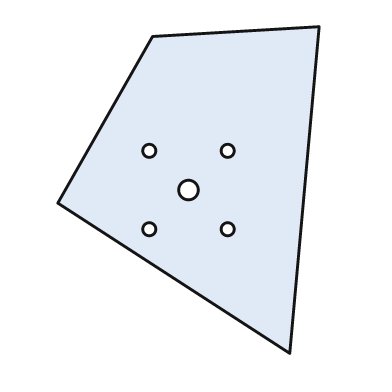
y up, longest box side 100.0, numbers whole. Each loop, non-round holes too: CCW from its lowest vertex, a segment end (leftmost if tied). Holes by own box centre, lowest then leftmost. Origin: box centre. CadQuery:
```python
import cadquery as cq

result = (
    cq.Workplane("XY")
    .moveTo(31.0, -50.0)
    .lineTo(40.0, 50.0)
    .lineTo(-11.0, 47.0)
    .lineTo(-40.0, -4.0)
    .close()
    .moveTo(-12.0, -12.0)
    .circle(2.0)
    .moveTo(12.0, -12.0)
    .circle(2.0)
    .moveTo(0.0, 0.0)
    .circle(3.0)
    .moveTo(-12.0, 12.0)
    .circle(2.0)
    .moveTo(12.0, 12.0)
    .circle(2.0)
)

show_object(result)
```